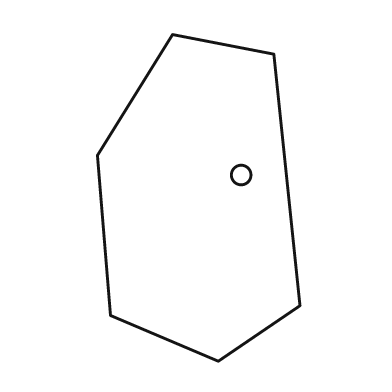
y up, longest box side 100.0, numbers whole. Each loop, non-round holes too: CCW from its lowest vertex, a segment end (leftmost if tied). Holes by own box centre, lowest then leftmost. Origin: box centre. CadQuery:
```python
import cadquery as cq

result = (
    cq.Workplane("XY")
    .moveTo(6.0, -50.0)
    .lineTo(31.0, -33.0)
    .lineTo(23.0, 44.0)
    .lineTo(-8.0, 50.0)
    .lineTo(-31.0, 13.0)
    .lineTo(-27.0, -36.0)
    .close()
    .moveTo(13.0, 7.0)
    .circle(3.0)
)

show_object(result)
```